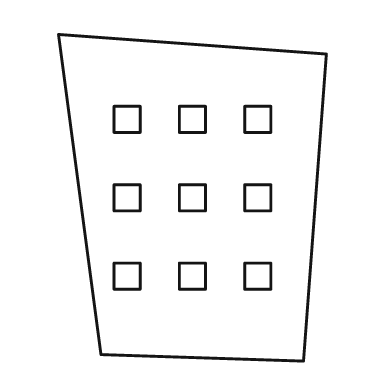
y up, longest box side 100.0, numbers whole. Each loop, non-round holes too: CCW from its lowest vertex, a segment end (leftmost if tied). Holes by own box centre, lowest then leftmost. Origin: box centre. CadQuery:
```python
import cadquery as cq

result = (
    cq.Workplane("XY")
    .moveTo(34.0, -50.0)
    .lineTo(41.0, 44.0)
    .lineTo(-41.0, 50.0)
    .lineTo(-28.0, -48.0)
    .close()
    .moveTo(-24.0, -28.0)
    .lineTo(-16.0, -28.0)
    .lineTo(-16.0, -20.0)
    .lineTo(-24.0, -20.0)
    .close()
    .moveTo(-4.0, -28.0)
    .lineTo(4.0, -28.0)
    .lineTo(4.0, -20.0)
    .lineTo(-4.0, -20.0)
    .close()
    .moveTo(16.0, -28.0)
    .lineTo(24.0, -28.0)
    .lineTo(24.0, -20.0)
    .lineTo(16.0, -20.0)
    .close()
    .moveTo(-24.0, -4.0)
    .lineTo(-16.0, -4.0)
    .lineTo(-16.0, 4.0)
    .lineTo(-24.0, 4.0)
    .close()
    .moveTo(-4.0, -4.0)
    .lineTo(4.0, -4.0)
    .lineTo(4.0, 4.0)
    .lineTo(-4.0, 4.0)
    .close()
    .moveTo(16.0, -4.0)
    .lineTo(24.0, -4.0)
    .lineTo(24.0, 4.0)
    .lineTo(16.0, 4.0)
    .close()
    .moveTo(-24.0, 20.0)
    .lineTo(-16.0, 20.0)
    .lineTo(-16.0, 28.0)
    .lineTo(-24.0, 28.0)
    .close()
    .moveTo(-4.0, 20.0)
    .lineTo(4.0, 20.0)
    .lineTo(4.0, 28.0)
    .lineTo(-4.0, 28.0)
    .close()
    .moveTo(16.0, 20.0)
    .lineTo(24.0, 20.0)
    .lineTo(24.0, 28.0)
    .lineTo(16.0, 28.0)
    .close()
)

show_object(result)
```